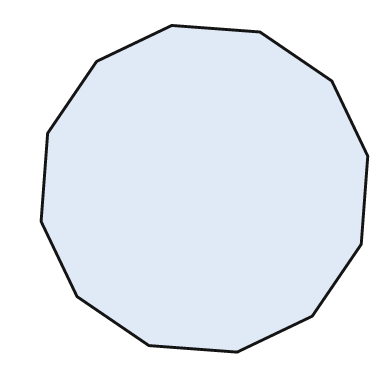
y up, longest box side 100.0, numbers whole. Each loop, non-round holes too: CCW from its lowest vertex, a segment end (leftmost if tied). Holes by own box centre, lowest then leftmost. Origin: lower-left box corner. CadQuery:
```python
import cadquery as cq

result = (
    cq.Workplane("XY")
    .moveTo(60.0, 0.0)
    .lineTo(83.0, 11.0)
    .lineTo(98.0, 33.0)
    .lineTo(100.0, 60.0)
    .lineTo(89.0, 83.0)
    .lineTo(67.0, 98.0)
    .lineTo(40.0, 100.0)
    .lineTo(17.0, 89.0)
    .lineTo(2.0, 67.0)
    .lineTo(0.0, 40.0)
    .lineTo(11.0, 17.0)
    .lineTo(33.0, 2.0)
    .close()
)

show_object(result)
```